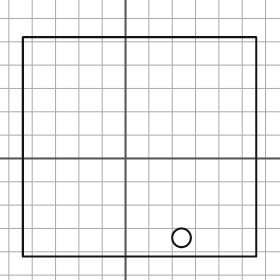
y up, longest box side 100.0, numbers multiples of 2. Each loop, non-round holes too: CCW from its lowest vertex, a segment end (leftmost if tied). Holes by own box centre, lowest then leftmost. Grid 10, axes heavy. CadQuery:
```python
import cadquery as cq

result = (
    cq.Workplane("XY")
    .moveTo(-44.0, -42.0)
    .lineTo(56.0, -42.0)
    .lineTo(56.0, 52.0)
    .lineTo(-44.0, 52.0)
    .close()
    .moveTo(24.0, -34.0)
    .circle(4.0)
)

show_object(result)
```